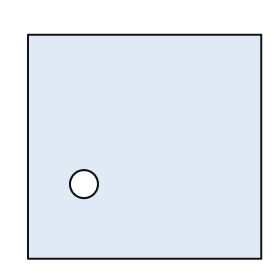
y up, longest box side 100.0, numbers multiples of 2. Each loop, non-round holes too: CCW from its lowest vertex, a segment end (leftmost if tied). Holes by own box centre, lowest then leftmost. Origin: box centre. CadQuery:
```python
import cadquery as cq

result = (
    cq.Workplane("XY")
    .moveTo(-50.0, -48.0)
    .lineTo(50.0, -48.0)
    .lineTo(50.0, 48.0)
    .lineTo(-50.0, 48.0)
    .close()
    .moveTo(-26.0, -16.0)
    .circle(6.0)
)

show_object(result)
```